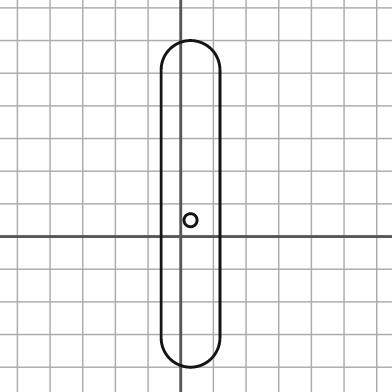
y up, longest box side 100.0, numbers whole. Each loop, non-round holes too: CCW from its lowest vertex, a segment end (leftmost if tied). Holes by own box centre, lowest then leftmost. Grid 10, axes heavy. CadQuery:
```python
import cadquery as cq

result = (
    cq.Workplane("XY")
    .moveTo(-6.0, -31.0)
    .threePointArc((3.0, -40.0), (12.0, -31.0))
    .lineTo(12.0, 51.0)
    .threePointArc((3.0, 60.0), (-6.0, 51.0))
    .close()
    .moveTo(3.0, 5.0)
    .circle(2.0)
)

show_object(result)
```